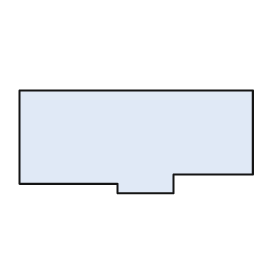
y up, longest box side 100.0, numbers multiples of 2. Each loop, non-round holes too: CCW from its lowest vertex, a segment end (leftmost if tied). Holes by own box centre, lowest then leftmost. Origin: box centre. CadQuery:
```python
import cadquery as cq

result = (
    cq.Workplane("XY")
    .moveTo(-8.0, -22.0)
    .lineTo(16.0, -22.0)
    .lineTo(16.0, -14.0)
    .lineTo(50.0, -14.0)
    .lineTo(50.0, 22.0)
    .lineTo(-50.0, 22.0)
    .lineTo(-50.0, -18.0)
    .lineTo(-8.0, -18.0)
    .close()
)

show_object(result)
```